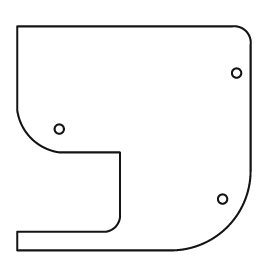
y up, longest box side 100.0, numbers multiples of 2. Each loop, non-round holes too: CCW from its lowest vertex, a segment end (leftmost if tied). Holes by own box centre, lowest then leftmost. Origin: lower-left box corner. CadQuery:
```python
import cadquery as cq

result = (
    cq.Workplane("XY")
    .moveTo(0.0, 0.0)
    .lineTo(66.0, 0.0)
    .threePointArc((90.0, 10.0), (100.0, 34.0))
    .lineTo(100.0, 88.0)
    .threePointArc((98.0, 94.0), (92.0, 96.0))
    .lineTo(0.0, 96.0)
    .lineTo(0.0, 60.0)
    .threePointArc((6.0, 48.0), (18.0, 42.0))
    .lineTo(44.0, 42.0)
    .lineTo(44.0, 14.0)
    .threePointArc((42.0, 10.0), (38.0, 8.0))
    .lineTo(0.0, 8.0)
    .close()
    .moveTo(88.0, 22.0)
    .circle(2.0)
    .moveTo(18.0, 52.0)
    .circle(2.0)
    .moveTo(94.0, 76.0)
    .circle(2.0)
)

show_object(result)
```